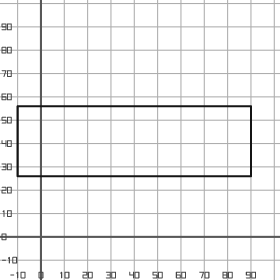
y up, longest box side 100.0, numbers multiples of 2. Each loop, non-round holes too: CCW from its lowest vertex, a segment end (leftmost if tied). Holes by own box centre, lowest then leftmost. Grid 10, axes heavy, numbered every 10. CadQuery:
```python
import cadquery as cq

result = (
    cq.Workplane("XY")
    .moveTo(-10.0, 26.0)
    .lineTo(90.0, 26.0)
    .lineTo(90.0, 56.0)
    .lineTo(-10.0, 56.0)
    .close()
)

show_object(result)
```